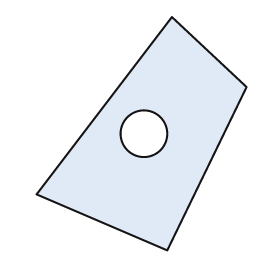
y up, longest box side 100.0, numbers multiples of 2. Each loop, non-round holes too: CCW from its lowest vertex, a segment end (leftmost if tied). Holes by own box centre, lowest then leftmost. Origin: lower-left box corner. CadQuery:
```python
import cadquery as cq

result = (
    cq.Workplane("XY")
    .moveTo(56.0, 0.0)
    .lineTo(90.0, 70.0)
    .lineTo(58.0, 100.0)
    .lineTo(0.0, 24.0)
    .close()
    .moveTo(46.0, 50.0)
    .circle(10.0)
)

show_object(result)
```